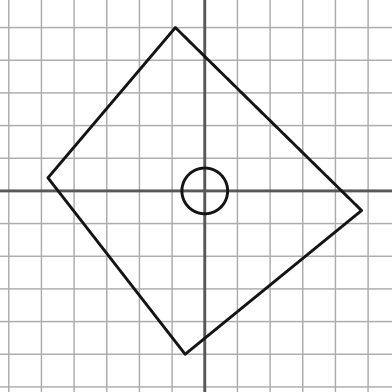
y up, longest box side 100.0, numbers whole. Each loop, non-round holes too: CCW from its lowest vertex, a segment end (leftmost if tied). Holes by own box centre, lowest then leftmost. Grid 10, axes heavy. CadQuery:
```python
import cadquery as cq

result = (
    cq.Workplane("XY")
    .moveTo(-6.0, -50.0)
    .lineTo(48.0, -6.0)
    .lineTo(-9.0, 50.0)
    .lineTo(-48.0, 4.0)
    .close()
    .moveTo(0.0, 0.0)
    .circle(7.0)
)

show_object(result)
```